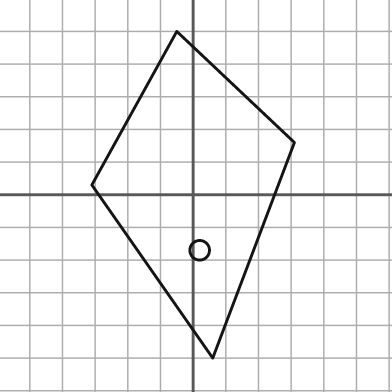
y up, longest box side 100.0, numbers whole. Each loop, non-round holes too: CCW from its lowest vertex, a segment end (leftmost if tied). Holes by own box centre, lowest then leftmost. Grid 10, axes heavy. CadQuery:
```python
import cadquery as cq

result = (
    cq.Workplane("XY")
    .moveTo(6.0, -50.0)
    .lineTo(31.0, 16.0)
    .lineTo(-5.0, 50.0)
    .lineTo(-31.0, 3.0)
    .close()
    .moveTo(2.0, -17.0)
    .circle(3.0)
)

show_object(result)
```